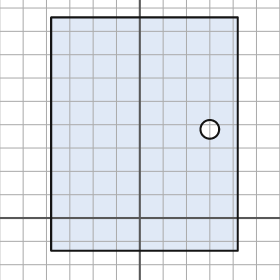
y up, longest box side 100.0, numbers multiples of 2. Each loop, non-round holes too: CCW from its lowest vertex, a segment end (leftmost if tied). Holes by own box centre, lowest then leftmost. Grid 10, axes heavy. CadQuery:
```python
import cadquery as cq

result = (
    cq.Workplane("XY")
    .moveTo(-38.0, -14.0)
    .lineTo(42.0, -14.0)
    .lineTo(42.0, 86.0)
    .lineTo(-38.0, 86.0)
    .close()
    .moveTo(30.0, 38.0)
    .circle(4.0)
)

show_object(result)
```